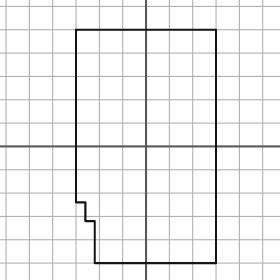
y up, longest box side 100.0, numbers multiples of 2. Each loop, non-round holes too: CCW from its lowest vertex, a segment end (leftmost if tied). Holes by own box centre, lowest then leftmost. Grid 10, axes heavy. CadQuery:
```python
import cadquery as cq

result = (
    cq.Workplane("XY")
    .moveTo(-22.0, -50.0)
    .lineTo(30.0, -50.0)
    .lineTo(30.0, 50.0)
    .lineTo(-30.0, 50.0)
    .lineTo(-30.0, -24.0)
    .lineTo(-26.0, -24.0)
    .lineTo(-26.0, -32.0)
    .lineTo(-22.0, -32.0)
    .close()
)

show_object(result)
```